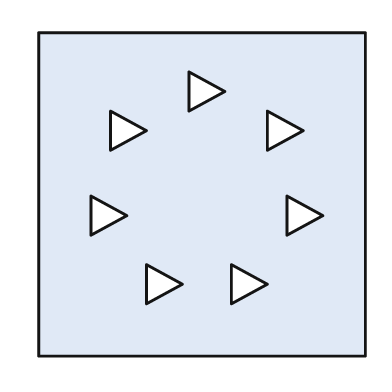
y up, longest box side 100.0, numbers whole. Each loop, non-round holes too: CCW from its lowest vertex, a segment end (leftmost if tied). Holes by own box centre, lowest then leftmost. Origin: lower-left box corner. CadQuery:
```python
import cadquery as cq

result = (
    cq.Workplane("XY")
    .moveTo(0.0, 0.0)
    .lineTo(100.0, 0.0)
    .lineTo(100.0, 99.0)
    .lineTo(0.0, 99.0)
    .close()
    .moveTo(33.0, 16.0)
    .lineTo(44.0, 22.0)
    .lineTo(33.0, 28.0)
    .close()
    .moveTo(59.0, 16.0)
    .lineTo(70.0, 22.0)
    .lineTo(59.0, 28.0)
    .close()
    .moveTo(16.0, 37.0)
    .lineTo(27.0, 43.0)
    .lineTo(16.0, 49.0)
    .close()
    .moveTo(76.0, 37.0)
    .lineTo(87.0, 43.0)
    .lineTo(76.0, 49.0)
    .close()
    .moveTo(22.0, 63.0)
    .lineTo(33.0, 69.0)
    .lineTo(22.0, 75.0)
    .close()
    .moveTo(70.0, 63.0)
    .lineTo(81.0, 69.0)
    .lineTo(70.0, 75.0)
    .close()
    .moveTo(46.0, 75.0)
    .lineTo(57.0, 81.0)
    .lineTo(46.0, 87.0)
    .close()
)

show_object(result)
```